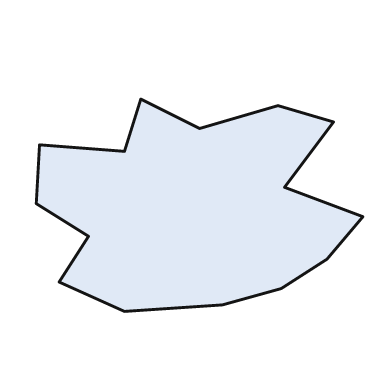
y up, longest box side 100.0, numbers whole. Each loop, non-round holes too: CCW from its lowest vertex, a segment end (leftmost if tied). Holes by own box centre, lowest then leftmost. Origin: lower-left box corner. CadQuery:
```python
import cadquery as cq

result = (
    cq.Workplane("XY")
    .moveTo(27.0, 0.0)
    .lineTo(57.0, 2.0)
    .lineTo(75.0, 7.0)
    .lineTo(89.0, 16.0)
    .lineTo(100.0, 29.0)
    .lineTo(76.0, 38.0)
    .lineTo(91.0, 58.0)
    .lineTo(74.0, 63.0)
    .lineTo(50.0, 56.0)
    .lineTo(32.0, 65.0)
    .lineTo(27.0, 49.0)
    .lineTo(1.0, 51.0)
    .lineTo(0.0, 33.0)
    .lineTo(16.0, 23.0)
    .lineTo(7.0, 9.0)
    .close()
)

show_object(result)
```